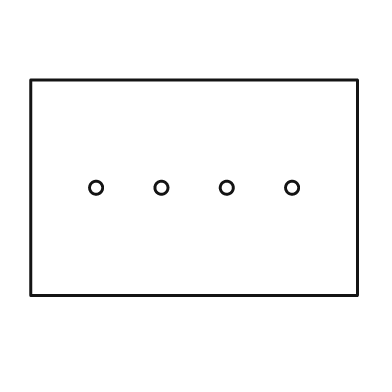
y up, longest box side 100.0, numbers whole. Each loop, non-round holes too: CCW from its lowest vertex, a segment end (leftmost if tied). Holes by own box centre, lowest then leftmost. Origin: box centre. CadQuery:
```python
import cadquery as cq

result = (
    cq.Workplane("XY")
    .moveTo(-50.0, -33.0)
    .lineTo(50.0, -33.0)
    .lineTo(50.0, 33.0)
    .lineTo(-50.0, 33.0)
    .close()
    .moveTo(-30.0, 0.0)
    .circle(2.0)
    .moveTo(-10.0, 0.0)
    .circle(2.0)
    .moveTo(10.0, 0.0)
    .circle(2.0)
    .moveTo(30.0, 0.0)
    .circle(2.0)
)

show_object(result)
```